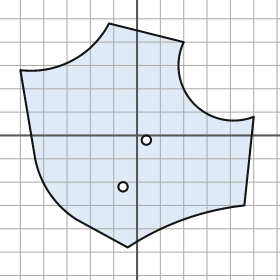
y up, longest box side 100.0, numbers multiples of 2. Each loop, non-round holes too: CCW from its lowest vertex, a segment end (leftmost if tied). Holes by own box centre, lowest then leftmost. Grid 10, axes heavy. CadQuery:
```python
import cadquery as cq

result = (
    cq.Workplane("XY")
    .moveTo(-4.0, -48.0)
    .threePointArc((20.0, -36.0), (46.0, -30.0))
    .lineTo(50.0, 8.0)
    .threePointArc((24.0, 14.0), (20.0, 40.0))
    .lineTo(-12.0, 48.0)
    .threePointArc((-28.0, 32.0), (-50.0, 28.0))
    .lineTo(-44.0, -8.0)
    .threePointArc((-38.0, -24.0), (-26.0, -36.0))
    .close()
    .moveTo(-6.0, -22.0)
    .circle(2.0)
    .moveTo(4.0, -2.0)
    .circle(2.0)
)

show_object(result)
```